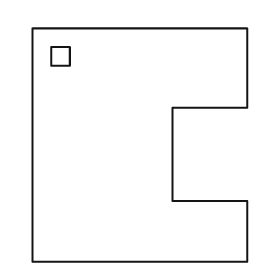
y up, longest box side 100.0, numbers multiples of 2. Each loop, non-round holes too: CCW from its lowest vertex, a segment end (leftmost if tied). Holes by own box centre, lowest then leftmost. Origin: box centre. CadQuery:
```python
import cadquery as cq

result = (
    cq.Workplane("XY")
    .moveTo(-46.0, -50.0)
    .lineTo(46.0, -50.0)
    .lineTo(46.0, -24.0)
    .lineTo(14.0, -24.0)
    .lineTo(14.0, 16.0)
    .lineTo(46.0, 16.0)
    .lineTo(46.0, 50.0)
    .lineTo(-46.0, 50.0)
    .close()
    .moveTo(-38.0, 34.0)
    .lineTo(-30.0, 34.0)
    .lineTo(-30.0, 42.0)
    .lineTo(-38.0, 42.0)
    .close()
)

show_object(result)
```